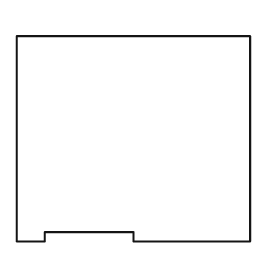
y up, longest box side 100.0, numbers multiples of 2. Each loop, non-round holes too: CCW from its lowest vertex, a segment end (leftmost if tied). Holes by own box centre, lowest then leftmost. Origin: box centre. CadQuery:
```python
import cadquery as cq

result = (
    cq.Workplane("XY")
    .moveTo(-50.0, -44.0)
    .lineTo(-38.0, -44.0)
    .lineTo(-38.0, -40.0)
    .lineTo(0.0, -40.0)
    .lineTo(0.0, -44.0)
    .lineTo(50.0, -44.0)
    .lineTo(50.0, 44.0)
    .lineTo(-50.0, 44.0)
    .close()
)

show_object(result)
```